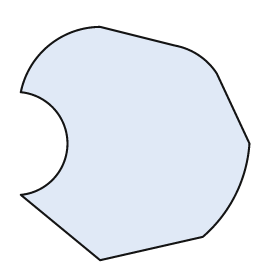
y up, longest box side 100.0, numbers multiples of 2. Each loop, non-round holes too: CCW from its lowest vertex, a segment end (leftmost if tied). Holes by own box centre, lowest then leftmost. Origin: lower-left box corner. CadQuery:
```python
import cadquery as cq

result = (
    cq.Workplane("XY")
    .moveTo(34.0, 0.0)
    .lineTo(78.0, 10.0)
    .threePointArc((92.0, 28.0), (98.0, 50.0))
    .lineTo(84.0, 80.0)
    .threePointArc((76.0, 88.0), (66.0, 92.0))
    .lineTo(34.0, 100.0)
    .threePointArc((12.0, 92.0), (0.0, 72.0))
    .threePointArc((20.0, 50.0), (0.0, 28.0))
    .close()
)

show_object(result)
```